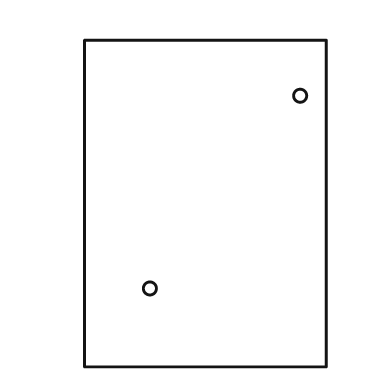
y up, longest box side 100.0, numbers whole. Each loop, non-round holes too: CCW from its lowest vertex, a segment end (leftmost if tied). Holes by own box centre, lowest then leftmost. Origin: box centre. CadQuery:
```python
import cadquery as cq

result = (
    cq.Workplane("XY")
    .moveTo(-37.0, -50.0)
    .lineTo(37.0, -50.0)
    .lineTo(37.0, 50.0)
    .lineTo(-37.0, 50.0)
    .close()
    .moveTo(-17.0, -26.0)
    .circle(2.0)
    .moveTo(29.0, 33.0)
    .circle(2.0)
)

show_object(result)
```